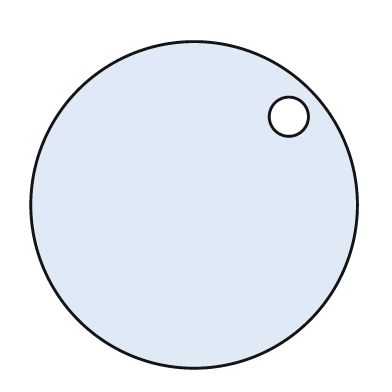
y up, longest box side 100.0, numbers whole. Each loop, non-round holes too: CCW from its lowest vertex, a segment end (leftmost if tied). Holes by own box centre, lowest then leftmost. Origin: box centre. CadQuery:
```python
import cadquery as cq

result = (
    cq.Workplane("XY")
    .moveTo(0.0, 0.0)
    .circle(50.0)
    .moveTo(29.0, 27.0)
    .circle(6.0)
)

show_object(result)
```